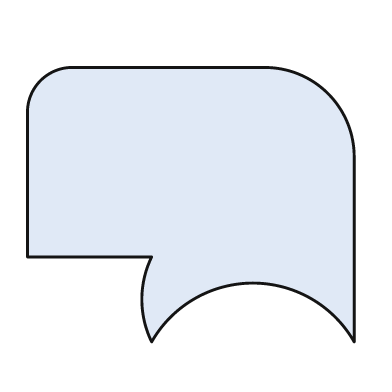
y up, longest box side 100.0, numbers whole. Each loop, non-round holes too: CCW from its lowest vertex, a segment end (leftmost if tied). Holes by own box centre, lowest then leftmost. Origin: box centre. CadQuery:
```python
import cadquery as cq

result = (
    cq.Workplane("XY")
    .moveTo(-12.0, -42.0)
    .threePointArc((19.0, -24.0), (50.0, -42.0))
    .lineTo(50.0, 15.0)
    .threePointArc((42.0, 34.0), (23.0, 42.0))
    .lineTo(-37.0, 42.0)
    .threePointArc((-46.0, 38.0), (-50.0, 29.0))
    .lineTo(-50.0, -16.0)
    .lineTo(-12.0, -16.0)
    .threePointArc((-15.0, -29.0), (-12.0, -42.0))
    .close()
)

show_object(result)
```